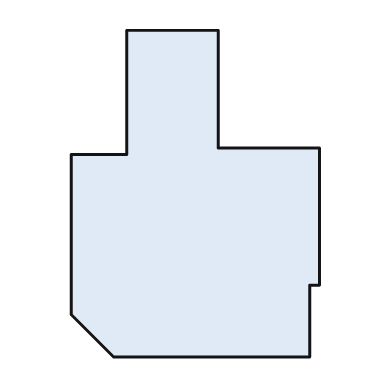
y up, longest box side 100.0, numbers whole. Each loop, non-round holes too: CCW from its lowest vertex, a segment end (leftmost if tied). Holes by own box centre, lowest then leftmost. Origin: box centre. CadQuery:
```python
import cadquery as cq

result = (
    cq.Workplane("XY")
    .moveTo(-25.0, -50.0)
    .lineTo(35.0, -50.0)
    .lineTo(35.0, -28.0)
    .lineTo(38.0, -28.0)
    .lineTo(38.0, 14.0)
    .lineTo(7.0, 14.0)
    .lineTo(7.0, 50.0)
    .lineTo(-21.0, 50.0)
    .lineTo(-21.0, 12.0)
    .lineTo(-38.0, 12.0)
    .lineTo(-38.0, -37.0)
    .close()
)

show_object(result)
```